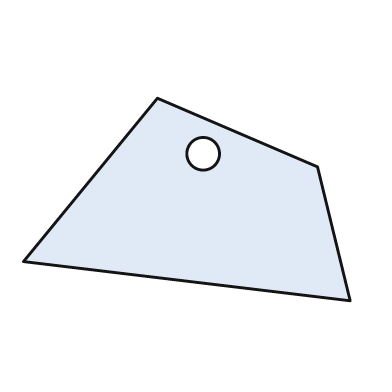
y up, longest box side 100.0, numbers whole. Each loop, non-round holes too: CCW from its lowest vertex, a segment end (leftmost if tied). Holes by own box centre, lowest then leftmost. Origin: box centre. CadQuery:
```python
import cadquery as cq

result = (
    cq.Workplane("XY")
    .moveTo(50.0, -31.0)
    .lineTo(40.0, 10.0)
    .lineTo(-9.0, 31.0)
    .lineTo(-50.0, -19.0)
    .close()
    .moveTo(5.0, 14.0)
    .circle(5.0)
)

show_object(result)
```